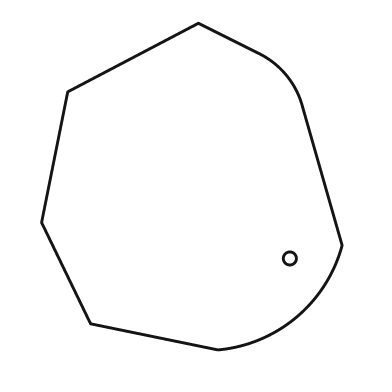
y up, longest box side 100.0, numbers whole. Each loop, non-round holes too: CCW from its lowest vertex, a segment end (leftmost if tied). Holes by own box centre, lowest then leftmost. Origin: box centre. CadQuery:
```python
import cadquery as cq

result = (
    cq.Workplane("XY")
    .moveTo(8.0, -50.0)
    .threePointArc((32.0, -40.0), (46.0, -18.0))
    .lineTo(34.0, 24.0)
    .threePointArc((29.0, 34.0), (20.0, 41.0))
    .lineTo(2.0, 50.0)
    .lineTo(-38.0, 29.0)
    .lineTo(-46.0, -11.0)
    .lineTo(-31.0, -42.0)
    .close()
    .moveTo(30.0, -22.0)
    .circle(2.0)
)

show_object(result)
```